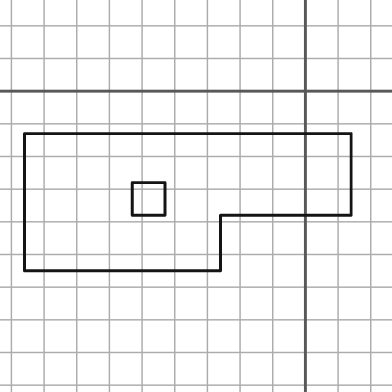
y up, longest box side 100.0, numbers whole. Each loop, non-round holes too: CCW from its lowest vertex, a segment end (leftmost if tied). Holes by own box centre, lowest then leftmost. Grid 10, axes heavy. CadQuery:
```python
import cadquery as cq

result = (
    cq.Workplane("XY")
    .moveTo(-86.0, -55.0)
    .lineTo(-26.0, -55.0)
    .lineTo(-26.0, -38.0)
    .lineTo(14.0, -38.0)
    .lineTo(14.0, -13.0)
    .lineTo(-86.0, -13.0)
    .close()
    .moveTo(-53.0, -38.0)
    .lineTo(-43.0, -38.0)
    .lineTo(-43.0, -28.0)
    .lineTo(-53.0, -28.0)
    .close()
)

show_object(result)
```